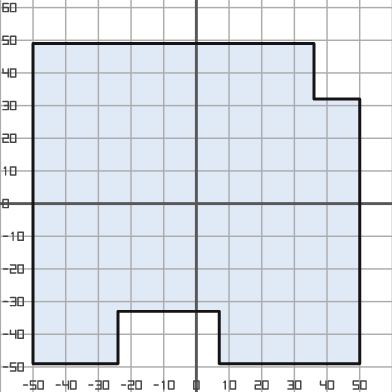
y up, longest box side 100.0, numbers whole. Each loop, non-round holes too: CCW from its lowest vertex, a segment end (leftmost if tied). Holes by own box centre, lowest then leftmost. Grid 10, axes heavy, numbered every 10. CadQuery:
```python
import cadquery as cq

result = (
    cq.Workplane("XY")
    .moveTo(-50.0, -49.0)
    .lineTo(-24.0, -49.0)
    .lineTo(-24.0, -33.0)
    .lineTo(7.0, -33.0)
    .lineTo(7.0, -49.0)
    .lineTo(50.0, -49.0)
    .lineTo(50.0, 32.0)
    .lineTo(36.0, 32.0)
    .lineTo(36.0, 49.0)
    .lineTo(-50.0, 49.0)
    .close()
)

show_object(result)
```